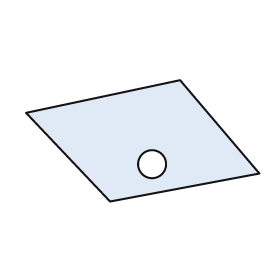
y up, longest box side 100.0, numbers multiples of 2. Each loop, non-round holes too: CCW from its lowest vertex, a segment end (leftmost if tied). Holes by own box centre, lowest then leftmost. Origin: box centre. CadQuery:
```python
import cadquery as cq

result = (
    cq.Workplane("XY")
    .moveTo(-14.0, -26.0)
    .lineTo(50.0, -14.0)
    .lineTo(16.0, 26.0)
    .lineTo(-50.0, 12.0)
    .close()
    .moveTo(4.0, -10.0)
    .circle(6.0)
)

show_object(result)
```